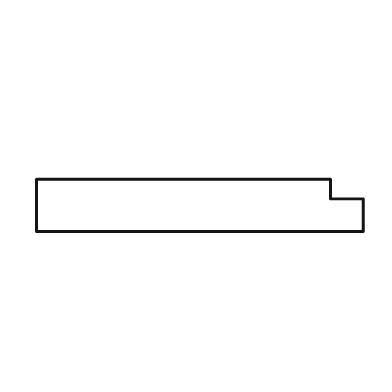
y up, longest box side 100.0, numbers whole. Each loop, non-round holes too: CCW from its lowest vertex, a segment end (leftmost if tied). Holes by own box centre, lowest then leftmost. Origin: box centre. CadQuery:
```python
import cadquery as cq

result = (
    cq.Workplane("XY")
    .moveTo(-50.0, -8.0)
    .lineTo(50.0, -8.0)
    .lineTo(50.0, 2.0)
    .lineTo(40.0, 2.0)
    .lineTo(40.0, 8.0)
    .lineTo(-50.0, 8.0)
    .close()
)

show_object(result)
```